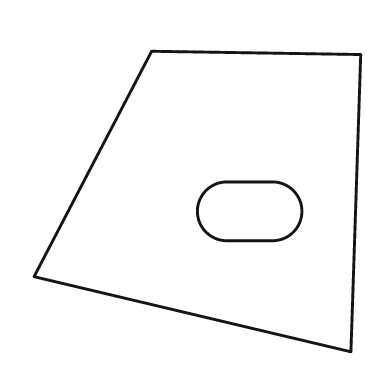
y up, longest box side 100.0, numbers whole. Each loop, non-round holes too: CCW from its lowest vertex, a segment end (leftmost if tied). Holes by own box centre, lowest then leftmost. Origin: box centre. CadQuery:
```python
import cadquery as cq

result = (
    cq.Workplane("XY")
    .moveTo(47.0, -46.0)
    .lineTo(50.0, 45.0)
    .lineTo(-14.0, 46.0)
    .lineTo(-50.0, -23.0)
    .close()
    .moveTo(9.0, -12.0)
    .lineTo(23.0, -12.0)
    .threePointArc((32.0, -3.0), (23.0, 6.0))
    .lineTo(9.0, 6.0)
    .threePointArc((0.0, -3.0), (9.0, -12.0))
    .close()
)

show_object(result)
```